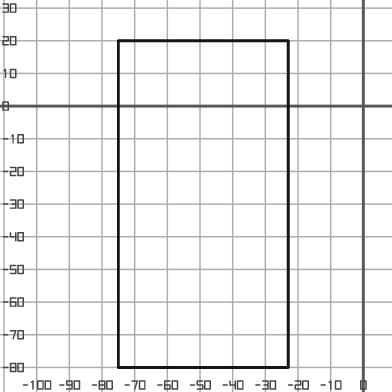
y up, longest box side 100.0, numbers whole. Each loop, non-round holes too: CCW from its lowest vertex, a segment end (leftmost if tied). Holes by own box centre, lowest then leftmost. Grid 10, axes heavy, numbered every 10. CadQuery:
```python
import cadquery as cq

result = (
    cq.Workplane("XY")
    .moveTo(-75.0, -80.0)
    .lineTo(-23.0, -80.0)
    .lineTo(-23.0, 20.0)
    .lineTo(-75.0, 20.0)
    .close()
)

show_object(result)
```